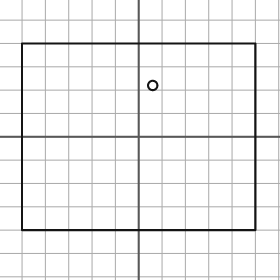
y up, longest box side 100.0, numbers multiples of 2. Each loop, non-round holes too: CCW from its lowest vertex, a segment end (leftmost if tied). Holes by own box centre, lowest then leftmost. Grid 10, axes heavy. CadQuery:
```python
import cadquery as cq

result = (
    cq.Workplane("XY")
    .moveTo(-50.0, -40.0)
    .lineTo(50.0, -40.0)
    .lineTo(50.0, 40.0)
    .lineTo(-50.0, 40.0)
    .close()
    .moveTo(6.0, 22.0)
    .circle(2.0)
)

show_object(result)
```